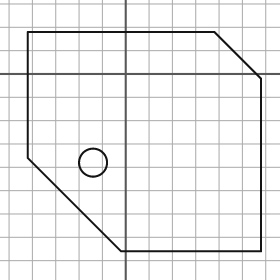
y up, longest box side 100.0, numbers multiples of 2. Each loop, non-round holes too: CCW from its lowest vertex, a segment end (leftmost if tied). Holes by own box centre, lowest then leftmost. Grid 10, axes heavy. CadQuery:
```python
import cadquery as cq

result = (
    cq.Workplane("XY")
    .moveTo(-2.0, -76.0)
    .lineTo(58.0, -76.0)
    .lineTo(58.0, -2.0)
    .lineTo(38.0, 18.0)
    .lineTo(-42.0, 18.0)
    .lineTo(-42.0, -36.0)
    .close()
    .moveTo(-14.0, -38.0)
    .circle(6.0)
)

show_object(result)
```